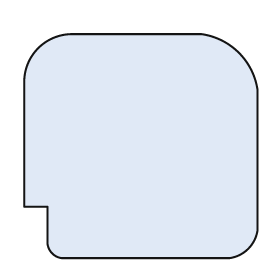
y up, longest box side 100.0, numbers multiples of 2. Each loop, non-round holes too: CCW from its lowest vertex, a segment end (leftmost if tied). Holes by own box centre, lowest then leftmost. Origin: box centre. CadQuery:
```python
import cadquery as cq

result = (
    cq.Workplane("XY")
    .moveTo(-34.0, -48.0)
    .lineTo(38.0, -48.0)
    .threePointArc((46.0, -44.0), (50.0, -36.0))
    .lineTo(50.0, 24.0)
    .threePointArc((42.0, 40.0), (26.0, 48.0))
    .lineTo(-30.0, 48.0)
    .threePointArc((-44.0, 42.0), (-50.0, 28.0))
    .lineTo(-50.0, -26.0)
    .lineTo(-40.0, -26.0)
    .lineTo(-40.0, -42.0)
    .threePointArc((-38.0, -46.0), (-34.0, -48.0))
    .close()
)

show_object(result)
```